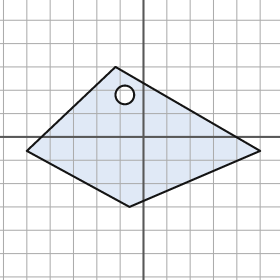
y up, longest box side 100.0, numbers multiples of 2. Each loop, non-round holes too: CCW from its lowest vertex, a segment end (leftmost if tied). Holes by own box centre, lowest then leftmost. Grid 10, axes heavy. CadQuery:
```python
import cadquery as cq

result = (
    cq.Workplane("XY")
    .moveTo(-6.0, -30.0)
    .lineTo(50.0, -6.0)
    .lineTo(-12.0, 30.0)
    .lineTo(-50.0, -6.0)
    .close()
    .moveTo(-8.0, 18.0)
    .circle(4.0)
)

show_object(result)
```